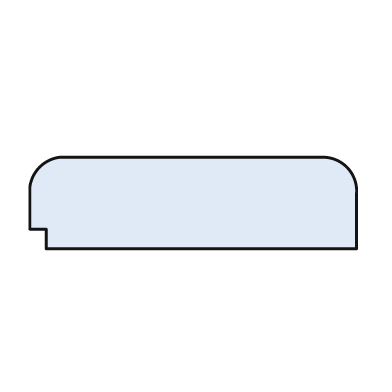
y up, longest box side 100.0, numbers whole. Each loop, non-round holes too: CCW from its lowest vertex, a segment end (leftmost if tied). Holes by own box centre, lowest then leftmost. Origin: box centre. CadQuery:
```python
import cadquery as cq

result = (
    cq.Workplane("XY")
    .moveTo(-45.0, -14.0)
    .lineTo(50.0, -14.0)
    .lineTo(50.0, 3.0)
    .threePointArc((47.0, 11.0), (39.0, 14.0))
    .lineTo(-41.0, 14.0)
    .threePointArc((-47.0, 11.0), (-50.0, 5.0))
    .lineTo(-50.0, -8.0)
    .lineTo(-45.0, -8.0)
    .close()
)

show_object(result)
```